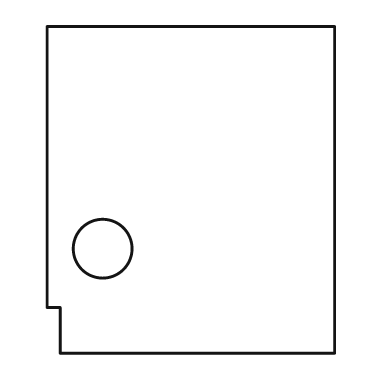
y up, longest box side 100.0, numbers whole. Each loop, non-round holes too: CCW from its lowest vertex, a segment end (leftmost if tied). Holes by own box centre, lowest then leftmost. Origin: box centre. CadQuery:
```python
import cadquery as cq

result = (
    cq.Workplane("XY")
    .moveTo(-40.0, -50.0)
    .lineTo(44.0, -50.0)
    .lineTo(44.0, 50.0)
    .lineTo(-44.0, 50.0)
    .lineTo(-44.0, -36.0)
    .lineTo(-40.0, -36.0)
    .close()
    .moveTo(-27.0, -18.0)
    .circle(9.0)
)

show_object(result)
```